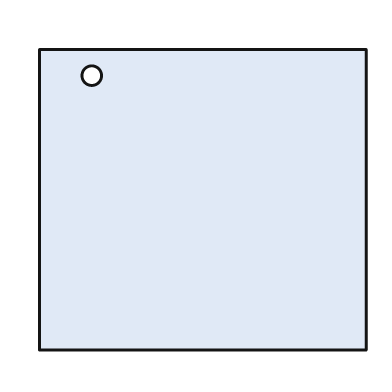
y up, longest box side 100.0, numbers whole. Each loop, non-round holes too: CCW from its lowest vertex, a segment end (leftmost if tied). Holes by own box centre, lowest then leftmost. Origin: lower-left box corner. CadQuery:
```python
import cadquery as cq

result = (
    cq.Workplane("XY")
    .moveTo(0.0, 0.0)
    .lineTo(100.0, 0.0)
    .lineTo(100.0, 92.0)
    .lineTo(0.0, 92.0)
    .close()
    .moveTo(16.0, 84.0)
    .circle(3.0)
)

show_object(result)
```